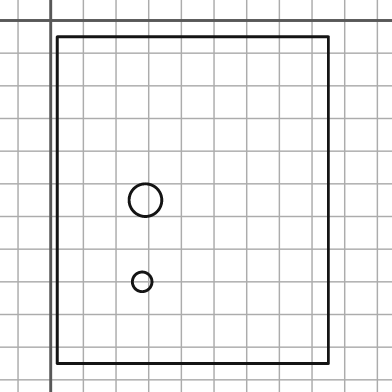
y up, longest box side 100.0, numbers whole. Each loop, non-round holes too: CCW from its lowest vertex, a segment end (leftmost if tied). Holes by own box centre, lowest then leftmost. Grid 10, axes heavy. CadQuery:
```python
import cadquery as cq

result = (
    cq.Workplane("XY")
    .moveTo(2.0, -105.0)
    .lineTo(85.0, -105.0)
    .lineTo(85.0, -5.0)
    .lineTo(2.0, -5.0)
    .close()
    .moveTo(28.0, -80.0)
    .circle(3.0)
    .moveTo(29.0, -55.0)
    .circle(5.0)
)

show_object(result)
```